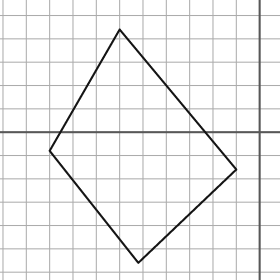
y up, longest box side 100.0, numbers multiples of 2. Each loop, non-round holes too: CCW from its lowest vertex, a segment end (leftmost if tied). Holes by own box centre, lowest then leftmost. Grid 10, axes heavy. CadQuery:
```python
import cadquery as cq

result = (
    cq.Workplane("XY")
    .moveTo(-52.0, -56.0)
    .lineTo(-10.0, -16.0)
    .lineTo(-60.0, 44.0)
    .lineTo(-90.0, -8.0)
    .close()
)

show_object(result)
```